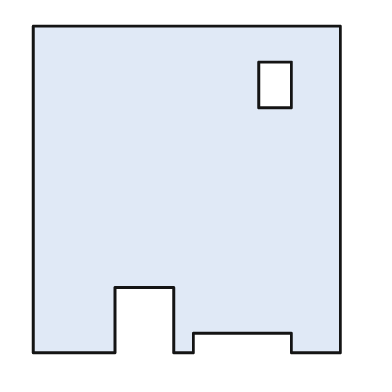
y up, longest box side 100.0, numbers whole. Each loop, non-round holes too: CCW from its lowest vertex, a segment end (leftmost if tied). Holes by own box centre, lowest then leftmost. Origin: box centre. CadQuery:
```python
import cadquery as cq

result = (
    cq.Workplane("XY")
    .moveTo(-47.0, -50.0)
    .lineTo(-22.0, -50.0)
    .lineTo(-22.0, -30.0)
    .lineTo(-4.0, -30.0)
    .lineTo(-4.0, -50.0)
    .lineTo(2.0, -50.0)
    .lineTo(2.0, -44.0)
    .lineTo(32.0, -44.0)
    .lineTo(32.0, -50.0)
    .lineTo(47.0, -50.0)
    .lineTo(47.0, 50.0)
    .lineTo(-47.0, 50.0)
    .close()
    .moveTo(22.0, 25.0)
    .lineTo(32.0, 25.0)
    .lineTo(32.0, 39.0)
    .lineTo(22.0, 39.0)
    .close()
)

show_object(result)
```